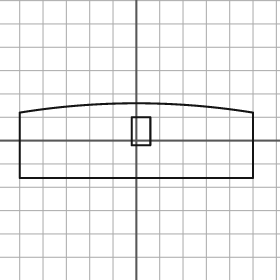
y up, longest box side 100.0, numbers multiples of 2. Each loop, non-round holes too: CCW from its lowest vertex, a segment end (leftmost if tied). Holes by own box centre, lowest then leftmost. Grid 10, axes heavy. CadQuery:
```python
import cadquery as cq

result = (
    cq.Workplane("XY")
    .moveTo(-50.0, -16.0)
    .lineTo(50.0, -16.0)
    .lineTo(50.0, 12.0)
    .threePointArc((0.0, 16.0), (-50.0, 12.0))
    .close()
    .moveTo(-2.0, -2.0)
    .lineTo(6.0, -2.0)
    .lineTo(6.0, 10.0)
    .lineTo(-2.0, 10.0)
    .close()
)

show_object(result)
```